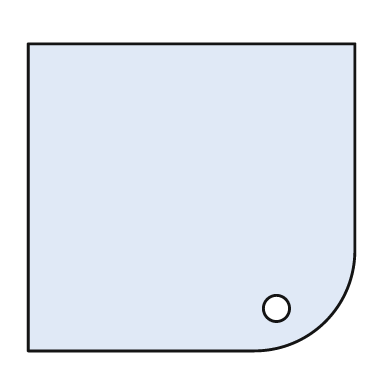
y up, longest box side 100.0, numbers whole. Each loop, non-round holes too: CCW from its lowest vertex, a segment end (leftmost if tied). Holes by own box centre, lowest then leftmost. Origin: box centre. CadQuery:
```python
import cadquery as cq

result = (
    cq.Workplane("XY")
    .moveTo(-50.0, -47.0)
    .lineTo(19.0, -47.0)
    .threePointArc((41.0, -38.0), (50.0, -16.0))
    .lineTo(50.0, 47.0)
    .lineTo(-50.0, 47.0)
    .close()
    .moveTo(26.0, -34.0)
    .circle(4.0)
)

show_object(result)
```